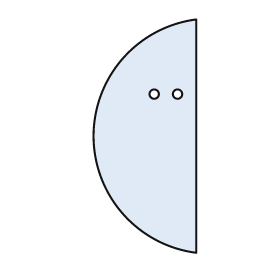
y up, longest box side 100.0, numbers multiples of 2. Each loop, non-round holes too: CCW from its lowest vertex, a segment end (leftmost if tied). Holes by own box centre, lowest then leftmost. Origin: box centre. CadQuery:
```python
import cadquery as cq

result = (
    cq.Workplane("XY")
    .moveTo(22.0, -50.0)
    .lineTo(22.0, 50.0)
    .threePointArc((-22.0, 0.0), (22.0, -50.0))
    .close()
    .moveTo(4.0, 18.0)
    .circle(2.0)
    .moveTo(14.0, 18.0)
    .circle(2.0)
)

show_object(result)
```